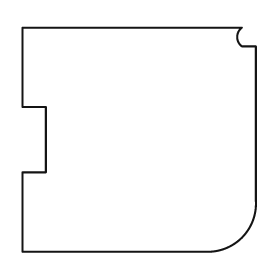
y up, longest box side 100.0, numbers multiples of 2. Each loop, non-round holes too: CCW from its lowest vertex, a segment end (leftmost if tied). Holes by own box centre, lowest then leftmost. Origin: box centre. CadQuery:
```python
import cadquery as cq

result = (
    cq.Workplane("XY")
    .moveTo(-50.0, -48.0)
    .lineTo(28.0, -48.0)
    .threePointArc((44.0, -42.0), (50.0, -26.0))
    .lineTo(50.0, 40.0)
    .lineTo(44.0, 40.0)
    .threePointArc((42.0, 44.0), (44.0, 48.0))
    .lineTo(-50.0, 48.0)
    .lineTo(-50.0, 14.0)
    .lineTo(-40.0, 14.0)
    .lineTo(-40.0, -14.0)
    .lineTo(-50.0, -14.0)
    .close()
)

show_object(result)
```